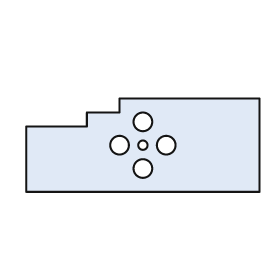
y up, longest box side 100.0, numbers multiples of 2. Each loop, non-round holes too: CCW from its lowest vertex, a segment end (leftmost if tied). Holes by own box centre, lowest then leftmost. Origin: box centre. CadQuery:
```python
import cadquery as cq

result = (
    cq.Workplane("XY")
    .moveTo(-50.0, -20.0)
    .lineTo(50.0, -20.0)
    .lineTo(50.0, 20.0)
    .lineTo(-10.0, 20.0)
    .lineTo(-10.0, 14.0)
    .lineTo(-24.0, 14.0)
    .lineTo(-24.0, 8.0)
    .lineTo(-50.0, 8.0)
    .close()
    .moveTo(0.0, -10.0)
    .circle(4.0)
    .moveTo(-10.0, 0.0)
    .circle(4.0)
    .moveTo(0.0, 0.0)
    .circle(2.0)
    .moveTo(10.0, 0.0)
    .circle(4.0)
    .moveTo(0.0, 10.0)
    .circle(4.0)
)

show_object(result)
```